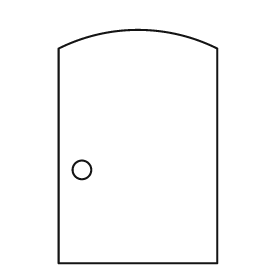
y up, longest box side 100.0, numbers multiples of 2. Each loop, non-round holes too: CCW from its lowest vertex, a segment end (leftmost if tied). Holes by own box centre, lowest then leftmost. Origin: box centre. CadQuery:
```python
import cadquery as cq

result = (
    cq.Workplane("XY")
    .moveTo(-34.0, -50.0)
    .lineTo(34.0, -50.0)
    .lineTo(34.0, 42.0)
    .threePointArc((0.0, 50.0), (-34.0, 42.0))
    .close()
    .moveTo(-24.0, -10.0)
    .circle(4.0)
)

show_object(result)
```